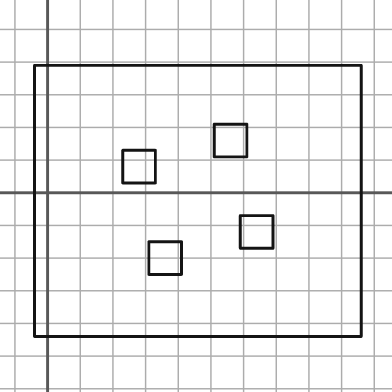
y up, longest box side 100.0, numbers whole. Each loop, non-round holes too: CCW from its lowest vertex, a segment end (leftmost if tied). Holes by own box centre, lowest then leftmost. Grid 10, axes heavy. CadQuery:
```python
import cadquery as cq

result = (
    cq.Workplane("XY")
    .moveTo(-4.0, -44.0)
    .lineTo(96.0, -44.0)
    .lineTo(96.0, 39.0)
    .lineTo(-4.0, 39.0)
    .close()
    .moveTo(31.0, -25.0)
    .lineTo(41.0, -25.0)
    .lineTo(41.0, -15.0)
    .lineTo(31.0, -15.0)
    .close()
    .moveTo(59.0, -17.0)
    .lineTo(69.0, -17.0)
    .lineTo(69.0, -7.0)
    .lineTo(59.0, -7.0)
    .close()
    .moveTo(23.0, 3.0)
    .lineTo(33.0, 3.0)
    .lineTo(33.0, 13.0)
    .lineTo(23.0, 13.0)
    .close()
    .moveTo(51.0, 11.0)
    .lineTo(61.0, 11.0)
    .lineTo(61.0, 21.0)
    .lineTo(51.0, 21.0)
    .close()
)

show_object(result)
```